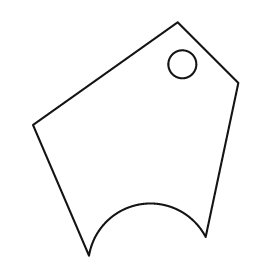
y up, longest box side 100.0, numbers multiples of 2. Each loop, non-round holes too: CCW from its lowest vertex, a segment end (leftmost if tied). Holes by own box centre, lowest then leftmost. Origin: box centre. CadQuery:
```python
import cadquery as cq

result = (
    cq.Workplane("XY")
    .moveTo(-20.0, -50.0)
    .threePointArc((2.0, -28.0), (30.0, -42.0))
    .lineTo(44.0, 24.0)
    .lineTo(18.0, 50.0)
    .lineTo(-44.0, 6.0)
    .close()
    .moveTo(20.0, 32.0)
    .circle(6.0)
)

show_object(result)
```